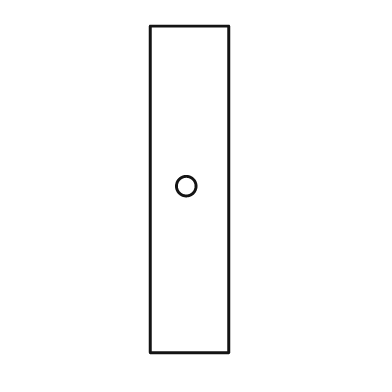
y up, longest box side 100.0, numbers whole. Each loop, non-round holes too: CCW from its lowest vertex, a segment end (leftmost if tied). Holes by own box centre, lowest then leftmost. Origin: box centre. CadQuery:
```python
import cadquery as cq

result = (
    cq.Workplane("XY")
    .moveTo(-12.0, -50.0)
    .lineTo(12.0, -50.0)
    .lineTo(12.0, 50.0)
    .lineTo(-12.0, 50.0)
    .close()
    .moveTo(-1.0, 1.0)
    .circle(3.0)
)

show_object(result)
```